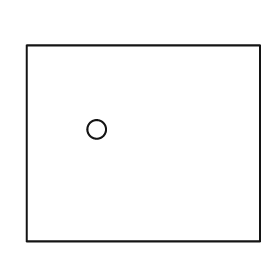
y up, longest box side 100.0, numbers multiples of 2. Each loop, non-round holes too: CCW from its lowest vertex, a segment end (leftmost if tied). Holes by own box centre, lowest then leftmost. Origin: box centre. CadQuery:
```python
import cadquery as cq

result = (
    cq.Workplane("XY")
    .moveTo(-50.0, -42.0)
    .lineTo(50.0, -42.0)
    .lineTo(50.0, 42.0)
    .lineTo(-50.0, 42.0)
    .close()
    .moveTo(-20.0, 6.0)
    .circle(4.0)
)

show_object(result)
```